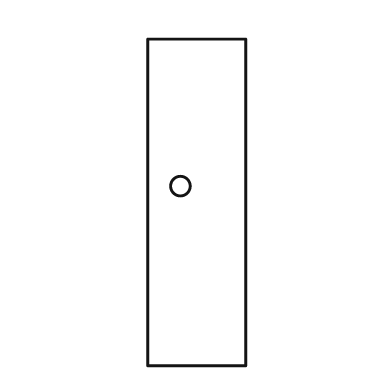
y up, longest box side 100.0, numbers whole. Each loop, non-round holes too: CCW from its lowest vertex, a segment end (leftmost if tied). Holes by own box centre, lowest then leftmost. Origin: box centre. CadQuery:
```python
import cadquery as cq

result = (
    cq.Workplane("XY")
    .moveTo(-15.0, -50.0)
    .lineTo(15.0, -50.0)
    .lineTo(15.0, 50.0)
    .lineTo(-15.0, 50.0)
    .close()
    .moveTo(-5.0, 5.0)
    .circle(3.0)
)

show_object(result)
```